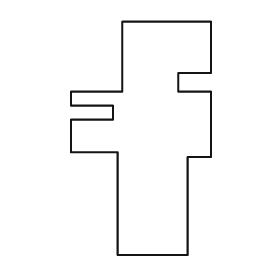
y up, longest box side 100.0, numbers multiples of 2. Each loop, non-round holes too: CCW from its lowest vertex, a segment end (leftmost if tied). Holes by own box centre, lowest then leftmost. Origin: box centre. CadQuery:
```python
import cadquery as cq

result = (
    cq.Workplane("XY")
    .moveTo(-10.0, -50.0)
    .lineTo(20.0, -50.0)
    .lineTo(20.0, -8.0)
    .lineTo(30.0, -8.0)
    .lineTo(30.0, 20.0)
    .lineTo(16.0, 20.0)
    .lineTo(16.0, 28.0)
    .lineTo(30.0, 28.0)
    .lineTo(30.0, 50.0)
    .lineTo(-8.0, 50.0)
    .lineTo(-8.0, 20.0)
    .lineTo(-30.0, 20.0)
    .lineTo(-30.0, 14.0)
    .lineTo(-12.0, 14.0)
    .lineTo(-12.0, 8.0)
    .lineTo(-30.0, 8.0)
    .lineTo(-30.0, -6.0)
    .lineTo(-10.0, -6.0)
    .close()
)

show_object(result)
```